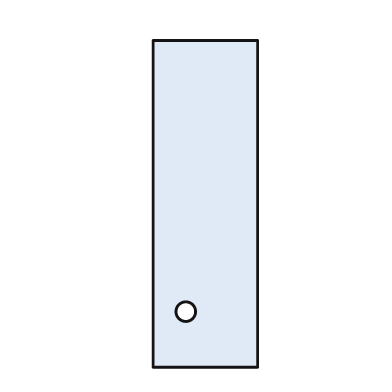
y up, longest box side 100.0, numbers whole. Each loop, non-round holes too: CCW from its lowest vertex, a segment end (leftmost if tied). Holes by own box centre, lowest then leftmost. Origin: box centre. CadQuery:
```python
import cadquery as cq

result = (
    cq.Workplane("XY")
    .moveTo(-16.0, -50.0)
    .lineTo(16.0, -50.0)
    .lineTo(16.0, 50.0)
    .lineTo(-16.0, 50.0)
    .close()
    .moveTo(-6.0, -33.0)
    .circle(3.0)
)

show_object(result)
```